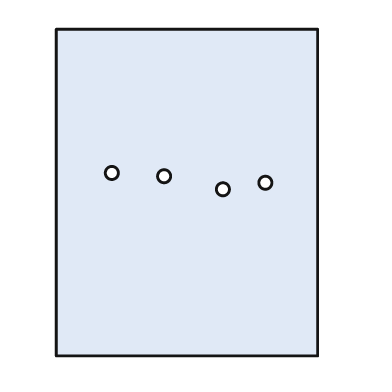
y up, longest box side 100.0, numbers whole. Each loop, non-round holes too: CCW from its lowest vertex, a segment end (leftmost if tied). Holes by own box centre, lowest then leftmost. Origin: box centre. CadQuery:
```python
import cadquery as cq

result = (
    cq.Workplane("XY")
    .moveTo(-40.0, -50.0)
    .lineTo(40.0, -50.0)
    .lineTo(40.0, 50.0)
    .lineTo(-40.0, 50.0)
    .close()
    .moveTo(11.0, 1.0)
    .circle(2.0)
    .moveTo(24.0, 3.0)
    .circle(2.0)
    .moveTo(-7.0, 5.0)
    .circle(2.0)
    .moveTo(-23.0, 6.0)
    .circle(2.0)
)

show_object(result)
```